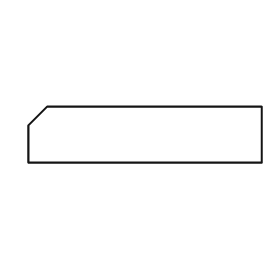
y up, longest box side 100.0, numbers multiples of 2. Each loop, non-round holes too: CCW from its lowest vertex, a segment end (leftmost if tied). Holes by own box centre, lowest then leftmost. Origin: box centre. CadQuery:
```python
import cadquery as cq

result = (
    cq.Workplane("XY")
    .moveTo(-50.0, -12.0)
    .lineTo(50.0, -12.0)
    .lineTo(50.0, 12.0)
    .lineTo(-42.0, 12.0)
    .lineTo(-50.0, 4.0)
    .close()
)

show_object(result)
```